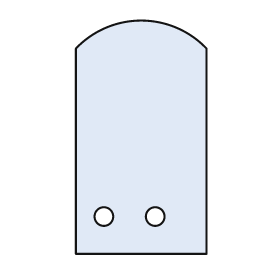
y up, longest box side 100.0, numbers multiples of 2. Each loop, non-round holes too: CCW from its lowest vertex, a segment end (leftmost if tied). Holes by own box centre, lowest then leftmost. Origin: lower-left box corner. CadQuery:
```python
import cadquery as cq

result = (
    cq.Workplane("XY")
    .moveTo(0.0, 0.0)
    .lineTo(56.0, 0.0)
    .lineTo(56.0, 88.0)
    .threePointArc((28.0, 100.0), (0.0, 88.0))
    .close()
    .moveTo(12.0, 16.0)
    .circle(4.0)
    .moveTo(34.0, 16.0)
    .circle(4.0)
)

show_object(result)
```